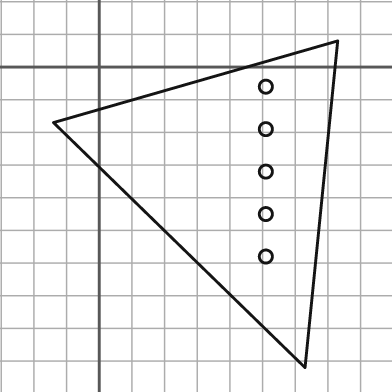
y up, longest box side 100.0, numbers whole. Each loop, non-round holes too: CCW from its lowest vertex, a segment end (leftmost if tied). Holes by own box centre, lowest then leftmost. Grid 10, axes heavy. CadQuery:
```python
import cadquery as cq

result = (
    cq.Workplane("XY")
    .moveTo(63.0, -92.0)
    .lineTo(73.0, 8.0)
    .lineTo(-14.0, -17.0)
    .close()
    .moveTo(51.0, -58.0)
    .circle(2.0)
    .moveTo(51.0, -45.0)
    .circle(2.0)
    .moveTo(51.0, -32.0)
    .circle(2.0)
    .moveTo(51.0, -19.0)
    .circle(2.0)
    .moveTo(51.0, -6.0)
    .circle(2.0)
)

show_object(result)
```